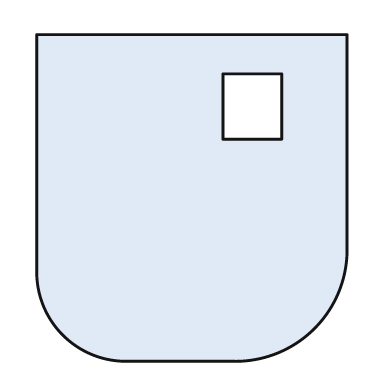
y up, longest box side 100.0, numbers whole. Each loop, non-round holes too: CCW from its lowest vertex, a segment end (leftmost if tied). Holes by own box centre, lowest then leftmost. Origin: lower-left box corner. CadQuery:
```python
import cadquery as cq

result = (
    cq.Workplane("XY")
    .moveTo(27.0, 0.0)
    .lineTo(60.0, 0.0)
    .threePointArc((85.0, 10.0), (95.0, 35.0))
    .lineTo(95.0, 100.0)
    .lineTo(0.0, 100.0)
    .lineTo(0.0, 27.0)
    .threePointArc((8.0, 8.0), (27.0, 0.0))
    .close()
    .moveTo(57.0, 68.0)
    .lineTo(75.0, 68.0)
    .lineTo(75.0, 88.0)
    .lineTo(57.0, 88.0)
    .close()
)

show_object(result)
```